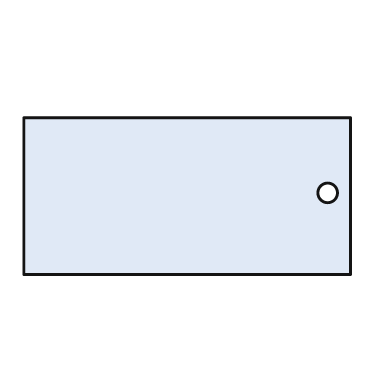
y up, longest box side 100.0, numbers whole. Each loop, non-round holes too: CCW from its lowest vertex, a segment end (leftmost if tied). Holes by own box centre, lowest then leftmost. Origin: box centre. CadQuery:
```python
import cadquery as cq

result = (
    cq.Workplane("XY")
    .moveTo(-50.0, -24.0)
    .lineTo(50.0, -24.0)
    .lineTo(50.0, 24.0)
    .lineTo(-50.0, 24.0)
    .close()
    .moveTo(43.0, 1.0)
    .circle(3.0)
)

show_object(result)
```